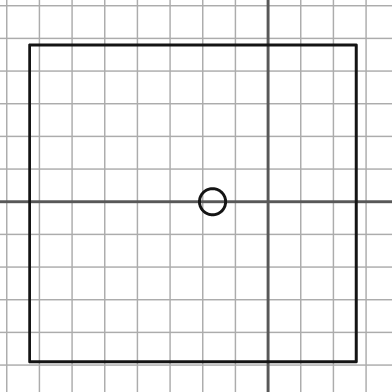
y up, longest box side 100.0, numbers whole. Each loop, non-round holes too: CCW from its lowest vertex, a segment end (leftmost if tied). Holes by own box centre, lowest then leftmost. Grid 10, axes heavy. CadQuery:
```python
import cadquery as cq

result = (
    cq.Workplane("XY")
    .moveTo(-73.0, -49.0)
    .lineTo(27.0, -49.0)
    .lineTo(27.0, 48.0)
    .lineTo(-73.0, 48.0)
    .close()
    .moveTo(-17.0, 0.0)
    .circle(4.0)
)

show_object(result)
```